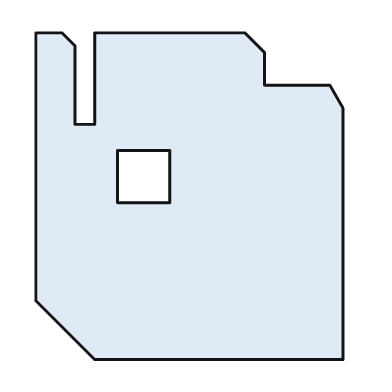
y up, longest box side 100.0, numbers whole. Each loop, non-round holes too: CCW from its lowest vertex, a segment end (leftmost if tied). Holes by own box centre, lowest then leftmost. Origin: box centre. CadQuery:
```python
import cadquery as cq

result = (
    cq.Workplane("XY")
    .moveTo(-29.0, -50.0)
    .lineTo(47.0, -50.0)
    .lineTo(47.0, 27.0)
    .lineTo(43.0, 34.0)
    .lineTo(23.0, 34.0)
    .lineTo(23.0, 44.0)
    .lineTo(17.0, 50.0)
    .lineTo(-29.0, 50.0)
    .lineTo(-29.0, 22.0)
    .lineTo(-35.0, 22.0)
    .lineTo(-35.0, 46.0)
    .lineTo(-39.0, 50.0)
    .lineTo(-47.0, 50.0)
    .lineTo(-47.0, -32.0)
    .close()
    .moveTo(-22.0, -2.0)
    .lineTo(-6.0, -2.0)
    .lineTo(-6.0, 14.0)
    .lineTo(-22.0, 14.0)
    .close()
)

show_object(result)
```